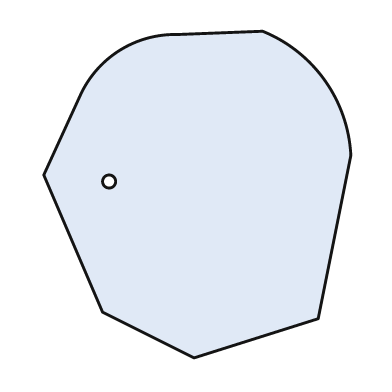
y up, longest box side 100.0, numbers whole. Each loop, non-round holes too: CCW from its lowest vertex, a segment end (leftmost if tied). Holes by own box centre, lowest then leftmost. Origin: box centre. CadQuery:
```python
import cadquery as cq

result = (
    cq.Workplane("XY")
    .moveTo(-1.0, -50.0)
    .lineTo(37.0, -38.0)
    .lineTo(47.0, 12.0)
    .threePointArc((39.0, 35.0), (20.0, 50.0))
    .lineTo(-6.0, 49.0)
    .threePointArc((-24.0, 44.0), (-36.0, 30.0))
    .lineTo(-47.0, 6.0)
    .lineTo(-29.0, -36.0)
    .close()
    .moveTo(-27.0, 4.0)
    .circle(2.0)
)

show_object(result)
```